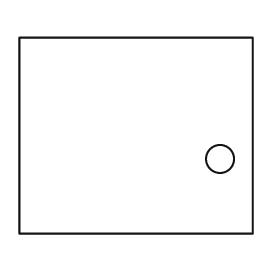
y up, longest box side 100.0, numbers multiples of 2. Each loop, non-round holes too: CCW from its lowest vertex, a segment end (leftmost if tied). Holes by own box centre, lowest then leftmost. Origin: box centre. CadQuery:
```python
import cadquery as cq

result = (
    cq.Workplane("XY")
    .moveTo(-50.0, -42.0)
    .lineTo(50.0, -42.0)
    .lineTo(50.0, 42.0)
    .lineTo(-50.0, 42.0)
    .close()
    .moveTo(36.0, -10.0)
    .circle(6.0)
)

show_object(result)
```